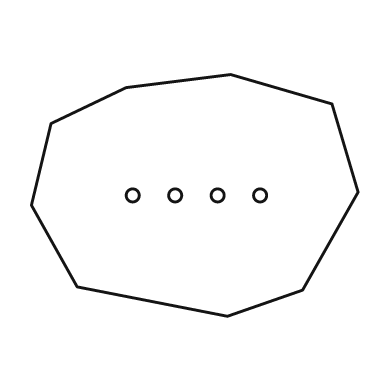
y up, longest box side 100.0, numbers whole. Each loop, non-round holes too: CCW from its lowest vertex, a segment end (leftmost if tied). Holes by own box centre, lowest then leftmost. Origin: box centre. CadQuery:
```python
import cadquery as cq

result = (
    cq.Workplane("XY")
    .moveTo(10.0, -37.0)
    .lineTo(33.0, -29.0)
    .lineTo(50.0, 1.0)
    .lineTo(42.0, 28.0)
    .lineTo(11.0, 37.0)
    .lineTo(-21.0, 33.0)
    .lineTo(-44.0, 22.0)
    .lineTo(-50.0, -3.0)
    .lineTo(-36.0, -28.0)
    .close()
    .moveTo(-19.0, 0.0)
    .circle(2.0)
    .moveTo(-6.0, 0.0)
    .circle(2.0)
    .moveTo(7.0, 0.0)
    .circle(2.0)
    .moveTo(20.0, 0.0)
    .circle(2.0)
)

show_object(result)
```